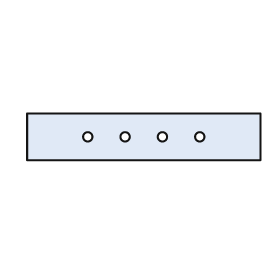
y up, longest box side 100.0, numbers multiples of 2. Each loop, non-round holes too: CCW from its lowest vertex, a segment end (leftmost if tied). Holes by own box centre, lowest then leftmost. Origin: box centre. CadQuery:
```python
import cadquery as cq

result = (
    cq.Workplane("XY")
    .moveTo(-50.0, -10.0)
    .lineTo(50.0, -10.0)
    .lineTo(50.0, 10.0)
    .lineTo(-50.0, 10.0)
    .close()
    .moveTo(-24.0, 0.0)
    .circle(2.0)
    .moveTo(-8.0, 0.0)
    .circle(2.0)
    .moveTo(8.0, 0.0)
    .circle(2.0)
    .moveTo(24.0, 0.0)
    .circle(2.0)
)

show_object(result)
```